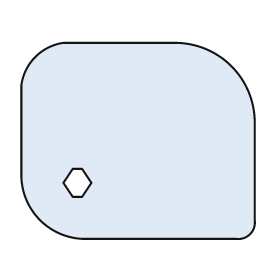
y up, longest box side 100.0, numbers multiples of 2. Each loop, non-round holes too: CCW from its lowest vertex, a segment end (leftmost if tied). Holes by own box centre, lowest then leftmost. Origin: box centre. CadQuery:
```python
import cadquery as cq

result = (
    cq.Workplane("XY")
    .moveTo(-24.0, -42.0)
    .lineTo(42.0, -42.0)
    .threePointArc((48.0, -40.0), (50.0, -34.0))
    .lineTo(50.0, 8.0)
    .threePointArc((40.0, 32.0), (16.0, 42.0))
    .lineTo(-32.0, 42.0)
    .threePointArc((-44.0, 36.0), (-50.0, 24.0))
    .lineTo(-50.0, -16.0)
    .threePointArc((-42.0, -34.0), (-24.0, -42.0))
    .close()
    .moveTo(-28.0, -24.0)
    .lineTo(-24.0, -24.0)
    .lineTo(-20.0, -18.0)
    .lineTo(-24.0, -12.0)
    .lineTo(-28.0, -12.0)
    .lineTo(-32.0, -18.0)
    .close()
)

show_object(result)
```